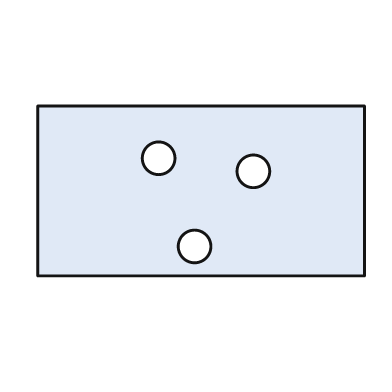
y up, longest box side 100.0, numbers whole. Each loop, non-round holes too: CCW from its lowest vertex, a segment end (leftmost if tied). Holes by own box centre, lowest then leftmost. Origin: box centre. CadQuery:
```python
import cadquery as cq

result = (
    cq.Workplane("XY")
    .moveTo(-50.0, -26.0)
    .lineTo(50.0, -26.0)
    .lineTo(50.0, 26.0)
    .lineTo(-50.0, 26.0)
    .close()
    .moveTo(-2.0, -17.0)
    .circle(5.0)
    .moveTo(16.0, 6.0)
    .circle(5.0)
    .moveTo(-13.0, 10.0)
    .circle(5.0)
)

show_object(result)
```